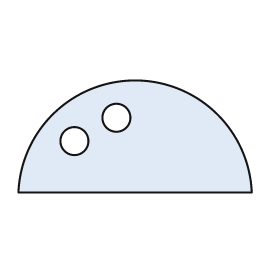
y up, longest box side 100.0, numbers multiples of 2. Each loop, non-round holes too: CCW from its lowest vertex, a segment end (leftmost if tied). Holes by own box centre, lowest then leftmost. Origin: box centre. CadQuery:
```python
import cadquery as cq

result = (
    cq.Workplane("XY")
    .moveTo(-50.0, -24.0)
    .lineTo(50.0, -24.0)
    .threePointArc((0.0, 24.0), (-50.0, -24.0))
    .close()
    .moveTo(-26.0, -2.0)
    .circle(6.0)
    .moveTo(-8.0, 8.0)
    .circle(6.0)
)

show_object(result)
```